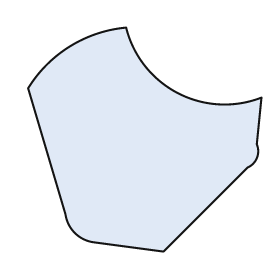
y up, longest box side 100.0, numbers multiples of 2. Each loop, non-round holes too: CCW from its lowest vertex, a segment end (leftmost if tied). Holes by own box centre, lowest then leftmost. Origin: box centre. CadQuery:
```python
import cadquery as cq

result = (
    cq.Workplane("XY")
    .moveTo(8.0, -48.0)
    .lineTo(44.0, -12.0)
    .threePointArc((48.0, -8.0), (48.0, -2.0))
    .lineTo(50.0, 18.0)
    .threePointArc((14.0, 20.0), (-8.0, 48.0))
    .threePointArc((-32.0, 40.0), (-50.0, 22.0))
    .lineTo(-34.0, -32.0)
    .threePointArc((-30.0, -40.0), (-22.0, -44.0))
    .close()
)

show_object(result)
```